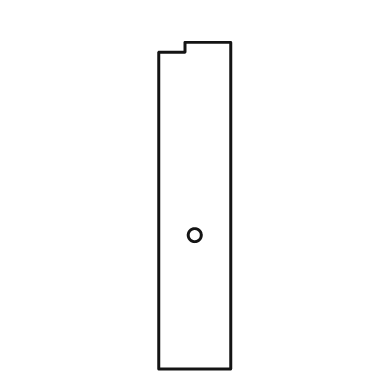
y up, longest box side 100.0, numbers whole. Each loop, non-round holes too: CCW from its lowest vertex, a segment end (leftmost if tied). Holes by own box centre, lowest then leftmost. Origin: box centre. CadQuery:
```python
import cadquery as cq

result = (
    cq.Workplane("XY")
    .moveTo(-11.0, -50.0)
    .lineTo(11.0, -50.0)
    .lineTo(11.0, 50.0)
    .lineTo(-3.0, 50.0)
    .lineTo(-3.0, 47.0)
    .lineTo(-11.0, 47.0)
    .close()
    .moveTo(0.0, -9.0)
    .circle(2.0)
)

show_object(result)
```